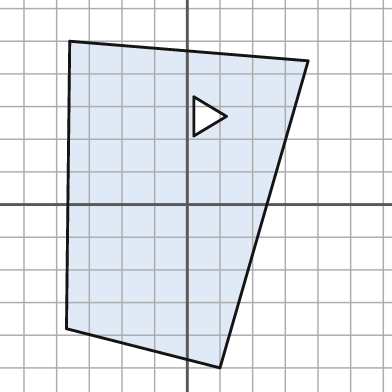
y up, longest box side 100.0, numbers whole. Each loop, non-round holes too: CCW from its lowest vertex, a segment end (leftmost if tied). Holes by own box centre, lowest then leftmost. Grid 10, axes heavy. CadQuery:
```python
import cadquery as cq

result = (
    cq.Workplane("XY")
    .moveTo(10.0, -50.0)
    .lineTo(37.0, 44.0)
    .lineTo(-36.0, 50.0)
    .lineTo(-37.0, -38.0)
    .close()
    .moveTo(2.0, 21.0)
    .lineTo(12.0, 27.0)
    .lineTo(2.0, 33.0)
    .close()
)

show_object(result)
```